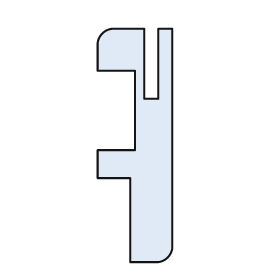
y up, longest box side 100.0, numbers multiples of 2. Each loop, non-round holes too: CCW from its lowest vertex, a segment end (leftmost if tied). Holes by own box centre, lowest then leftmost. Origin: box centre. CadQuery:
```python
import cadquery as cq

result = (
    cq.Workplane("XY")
    .moveTo(-2.0, -50.0)
    .lineTo(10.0, -50.0)
    .threePointArc((14.0, -48.0), (16.0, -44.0))
    .lineTo(16.0, 50.0)
    .lineTo(10.0, 50.0)
    .lineTo(10.0, 20.0)
    .lineTo(4.0, 20.0)
    .lineTo(4.0, 50.0)
    .lineTo(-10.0, 50.0)
    .threePointArc((-14.0, 48.0), (-16.0, 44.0))
    .lineTo(-16.0, 32.0)
    .lineTo(0.0, 32.0)
    .lineTo(0.0, -2.0)
    .lineTo(-16.0, -2.0)
    .lineTo(-16.0, -14.0)
    .lineTo(-2.0, -14.0)
    .close()
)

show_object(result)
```